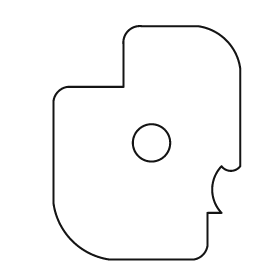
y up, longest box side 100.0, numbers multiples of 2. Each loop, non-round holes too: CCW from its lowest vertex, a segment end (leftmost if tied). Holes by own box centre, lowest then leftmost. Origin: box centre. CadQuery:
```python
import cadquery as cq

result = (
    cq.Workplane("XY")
    .moveTo(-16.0, -50.0)
    .lineTo(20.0, -50.0)
    .threePointArc((24.0, -48.0), (26.0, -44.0))
    .lineTo(26.0, -30.0)
    .lineTo(32.0, -30.0)
    .threePointArc((28.0, -20.0), (32.0, -10.0))
    .threePointArc((36.0, -12.0), (40.0, -10.0))
    .lineTo(40.0, 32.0)
    .threePointArc((34.0, 44.0), (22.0, 50.0))
    .lineTo(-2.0, 50.0)
    .threePointArc((-8.0, 48.0), (-10.0, 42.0))
    .lineTo(-10.0, 24.0)
    .lineTo(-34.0, 24.0)
    .threePointArc((-38.0, 22.0), (-40.0, 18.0))
    .lineTo(-40.0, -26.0)
    .threePointArc((-32.0, -42.0), (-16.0, -50.0))
    .close()
    .moveTo(2.0, 0.0)
    .circle(8.0)
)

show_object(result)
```